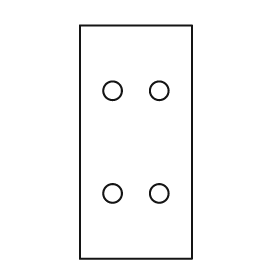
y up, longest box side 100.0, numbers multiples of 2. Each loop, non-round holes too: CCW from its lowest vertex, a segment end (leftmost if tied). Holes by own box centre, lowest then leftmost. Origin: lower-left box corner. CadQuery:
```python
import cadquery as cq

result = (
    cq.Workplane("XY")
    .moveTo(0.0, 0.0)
    .lineTo(48.0, 0.0)
    .lineTo(48.0, 100.0)
    .lineTo(0.0, 100.0)
    .close()
    .moveTo(14.0, 28.0)
    .circle(4.0)
    .moveTo(34.0, 28.0)
    .circle(4.0)
    .moveTo(14.0, 72.0)
    .circle(4.0)
    .moveTo(34.0, 72.0)
    .circle(4.0)
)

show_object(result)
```